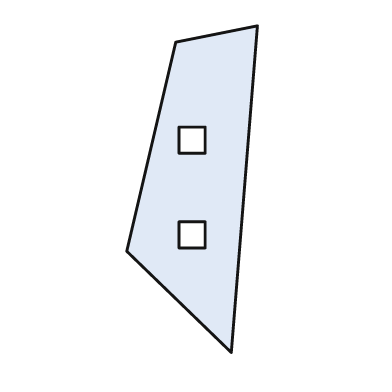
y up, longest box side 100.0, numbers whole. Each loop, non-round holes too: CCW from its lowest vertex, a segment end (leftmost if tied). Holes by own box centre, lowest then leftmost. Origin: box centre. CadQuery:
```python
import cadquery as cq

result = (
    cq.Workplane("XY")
    .moveTo(12.0, -50.0)
    .lineTo(20.0, 50.0)
    .lineTo(-5.0, 45.0)
    .lineTo(-20.0, -19.0)
    .close()
    .moveTo(-4.0, -18.0)
    .lineTo(4.0, -18.0)
    .lineTo(4.0, -10.0)
    .lineTo(-4.0, -10.0)
    .close()
    .moveTo(-4.0, 11.0)
    .lineTo(4.0, 11.0)
    .lineTo(4.0, 19.0)
    .lineTo(-4.0, 19.0)
    .close()
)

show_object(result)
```